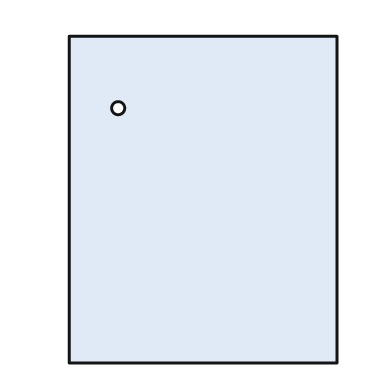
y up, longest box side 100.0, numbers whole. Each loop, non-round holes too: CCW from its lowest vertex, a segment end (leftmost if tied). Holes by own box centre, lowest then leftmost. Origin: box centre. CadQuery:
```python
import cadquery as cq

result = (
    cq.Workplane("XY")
    .moveTo(-41.0, -50.0)
    .lineTo(41.0, -50.0)
    .lineTo(41.0, 50.0)
    .lineTo(-41.0, 50.0)
    .close()
    .moveTo(-26.0, 28.0)
    .circle(2.0)
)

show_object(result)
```